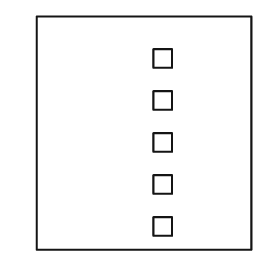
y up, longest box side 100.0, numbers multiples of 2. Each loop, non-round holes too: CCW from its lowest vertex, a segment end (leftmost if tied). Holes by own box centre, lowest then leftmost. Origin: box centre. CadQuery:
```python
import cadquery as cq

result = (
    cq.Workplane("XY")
    .moveTo(-46.0, -50.0)
    .lineTo(46.0, -50.0)
    .lineTo(46.0, 50.0)
    .lineTo(-46.0, 50.0)
    .close()
    .moveTo(4.0, -44.0)
    .lineTo(12.0, -44.0)
    .lineTo(12.0, -36.0)
    .lineTo(4.0, -36.0)
    .close()
    .moveTo(4.0, -26.0)
    .lineTo(12.0, -26.0)
    .lineTo(12.0, -18.0)
    .lineTo(4.0, -18.0)
    .close()
    .moveTo(4.0, -8.0)
    .lineTo(12.0, -8.0)
    .lineTo(12.0, 0.0)
    .lineTo(4.0, 0.0)
    .close()
    .moveTo(4.0, 10.0)
    .lineTo(12.0, 10.0)
    .lineTo(12.0, 18.0)
    .lineTo(4.0, 18.0)
    .close()
    .moveTo(4.0, 28.0)
    .lineTo(12.0, 28.0)
    .lineTo(12.0, 36.0)
    .lineTo(4.0, 36.0)
    .close()
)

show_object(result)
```